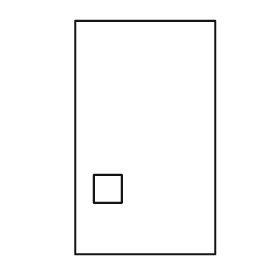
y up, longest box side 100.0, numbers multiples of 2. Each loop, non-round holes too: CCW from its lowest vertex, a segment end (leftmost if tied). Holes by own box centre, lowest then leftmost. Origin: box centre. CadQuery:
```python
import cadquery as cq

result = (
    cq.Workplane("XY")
    .moveTo(-30.0, -50.0)
    .lineTo(30.0, -50.0)
    .lineTo(30.0, 50.0)
    .lineTo(-30.0, 50.0)
    .close()
    .moveTo(-22.0, -28.0)
    .lineTo(-10.0, -28.0)
    .lineTo(-10.0, -16.0)
    .lineTo(-22.0, -16.0)
    .close()
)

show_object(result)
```